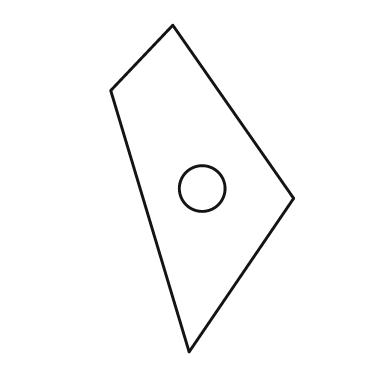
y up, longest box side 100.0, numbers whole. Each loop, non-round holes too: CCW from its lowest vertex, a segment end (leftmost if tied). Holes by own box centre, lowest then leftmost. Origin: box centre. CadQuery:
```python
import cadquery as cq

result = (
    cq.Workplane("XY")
    .moveTo(-4.0, -50.0)
    .lineTo(28.0, -3.0)
    .lineTo(-9.0, 50.0)
    .lineTo(-28.0, 30.0)
    .close()
    .moveTo(0.0, 0.0)
    .circle(7.0)
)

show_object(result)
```